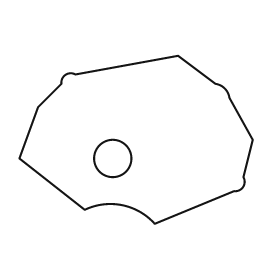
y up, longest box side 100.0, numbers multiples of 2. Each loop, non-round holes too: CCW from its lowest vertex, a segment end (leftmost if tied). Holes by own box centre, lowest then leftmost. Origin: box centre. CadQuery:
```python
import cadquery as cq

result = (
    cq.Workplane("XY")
    .moveTo(8.0, -36.0)
    .lineTo(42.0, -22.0)
    .threePointArc((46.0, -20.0), (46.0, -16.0))
    .lineTo(50.0, 0.0)
    .lineTo(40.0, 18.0)
    .threePointArc((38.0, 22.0), (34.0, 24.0))
    .lineTo(18.0, 36.0)
    .lineTo(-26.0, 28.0)
    .threePointArc((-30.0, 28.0), (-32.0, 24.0))
    .lineTo(-42.0, 14.0)
    .lineTo(-50.0, -8.0)
    .lineTo(-22.0, -30.0)
    .threePointArc((-6.0, -28.0), (8.0, -36.0))
    .close()
    .moveTo(-10.0, -8.0)
    .circle(8.0)
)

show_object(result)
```